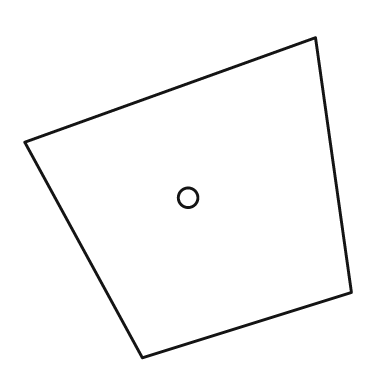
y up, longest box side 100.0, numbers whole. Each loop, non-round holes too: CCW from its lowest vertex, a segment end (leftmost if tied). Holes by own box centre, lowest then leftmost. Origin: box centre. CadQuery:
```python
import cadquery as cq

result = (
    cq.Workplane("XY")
    .moveTo(-14.0, -49.0)
    .lineTo(50.0, -29.0)
    .lineTo(39.0, 49.0)
    .lineTo(-50.0, 17.0)
    .close()
    .moveTo(0.0, 0.0)
    .circle(3.0)
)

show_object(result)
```